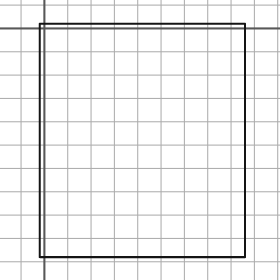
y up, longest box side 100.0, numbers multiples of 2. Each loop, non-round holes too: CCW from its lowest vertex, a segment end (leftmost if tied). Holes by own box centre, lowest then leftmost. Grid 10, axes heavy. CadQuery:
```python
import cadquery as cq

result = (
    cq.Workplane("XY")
    .moveTo(-2.0, -98.0)
    .lineTo(86.0, -98.0)
    .lineTo(86.0, 2.0)
    .lineTo(-2.0, 2.0)
    .close()
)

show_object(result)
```